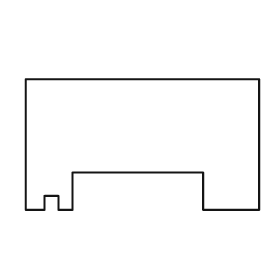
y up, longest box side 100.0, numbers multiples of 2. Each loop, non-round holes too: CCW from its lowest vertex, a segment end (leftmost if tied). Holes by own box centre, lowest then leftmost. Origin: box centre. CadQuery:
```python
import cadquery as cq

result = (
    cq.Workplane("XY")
    .moveTo(-50.0, -28.0)
    .lineTo(-42.0, -28.0)
    .lineTo(-42.0, -22.0)
    .lineTo(-36.0, -22.0)
    .lineTo(-36.0, -28.0)
    .lineTo(-30.0, -28.0)
    .lineTo(-30.0, -12.0)
    .lineTo(26.0, -12.0)
    .lineTo(26.0, -28.0)
    .lineTo(50.0, -28.0)
    .lineTo(50.0, 28.0)
    .lineTo(-50.0, 28.0)
    .close()
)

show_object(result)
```